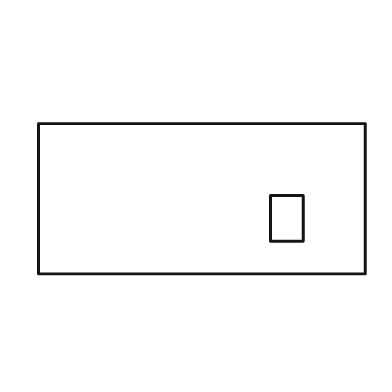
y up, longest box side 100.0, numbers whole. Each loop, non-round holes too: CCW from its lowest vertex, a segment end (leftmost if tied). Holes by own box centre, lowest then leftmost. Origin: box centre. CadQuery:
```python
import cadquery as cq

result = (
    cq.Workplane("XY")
    .moveTo(-50.0, -23.0)
    .lineTo(50.0, -23.0)
    .lineTo(50.0, 23.0)
    .lineTo(-50.0, 23.0)
    .close()
    .moveTo(21.0, -13.0)
    .lineTo(31.0, -13.0)
    .lineTo(31.0, 1.0)
    .lineTo(21.0, 1.0)
    .close()
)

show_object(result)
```